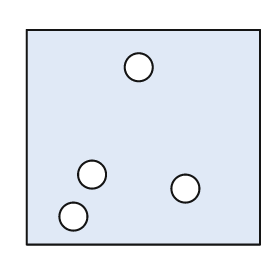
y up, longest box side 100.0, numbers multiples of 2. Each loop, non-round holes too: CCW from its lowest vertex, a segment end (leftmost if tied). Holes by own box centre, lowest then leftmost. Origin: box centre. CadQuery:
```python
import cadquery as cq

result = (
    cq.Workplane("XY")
    .moveTo(-50.0, -46.0)
    .lineTo(50.0, -46.0)
    .lineTo(50.0, 46.0)
    .lineTo(-50.0, 46.0)
    .close()
    .moveTo(-30.0, -34.0)
    .circle(6.0)
    .moveTo(18.0, -22.0)
    .circle(6.0)
    .moveTo(-22.0, -16.0)
    .circle(6.0)
    .moveTo(-2.0, 30.0)
    .circle(6.0)
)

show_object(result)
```